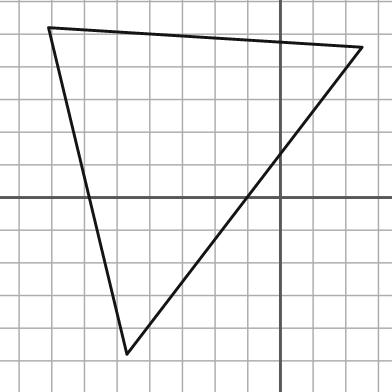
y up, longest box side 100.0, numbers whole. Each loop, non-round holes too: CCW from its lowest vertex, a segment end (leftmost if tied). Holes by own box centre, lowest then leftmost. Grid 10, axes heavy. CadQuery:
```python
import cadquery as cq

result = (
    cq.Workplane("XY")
    .moveTo(-47.0, -48.0)
    .lineTo(25.0, 46.0)
    .lineTo(-71.0, 52.0)
    .close()
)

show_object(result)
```